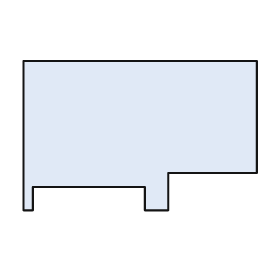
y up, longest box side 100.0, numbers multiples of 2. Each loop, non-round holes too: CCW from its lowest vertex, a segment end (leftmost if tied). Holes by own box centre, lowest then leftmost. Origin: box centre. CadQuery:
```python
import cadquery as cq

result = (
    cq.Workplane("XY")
    .moveTo(-50.0, -32.0)
    .lineTo(-46.0, -32.0)
    .lineTo(-46.0, -22.0)
    .lineTo(2.0, -22.0)
    .lineTo(2.0, -32.0)
    .lineTo(12.0, -32.0)
    .lineTo(12.0, -16.0)
    .lineTo(50.0, -16.0)
    .lineTo(50.0, 32.0)
    .lineTo(-50.0, 32.0)
    .close()
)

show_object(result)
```